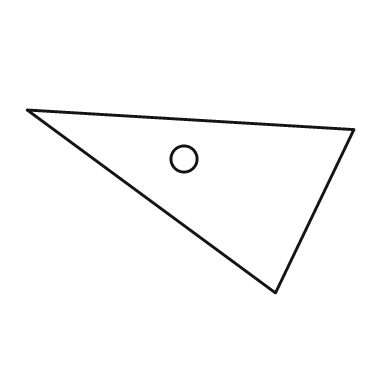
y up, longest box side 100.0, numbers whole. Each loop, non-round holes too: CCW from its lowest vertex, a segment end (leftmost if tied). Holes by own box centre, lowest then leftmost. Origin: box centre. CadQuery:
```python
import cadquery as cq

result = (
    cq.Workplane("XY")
    .moveTo(26.0, -28.0)
    .lineTo(50.0, 22.0)
    .lineTo(-50.0, 28.0)
    .close()
    .moveTo(-2.0, 13.0)
    .circle(4.0)
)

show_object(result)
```